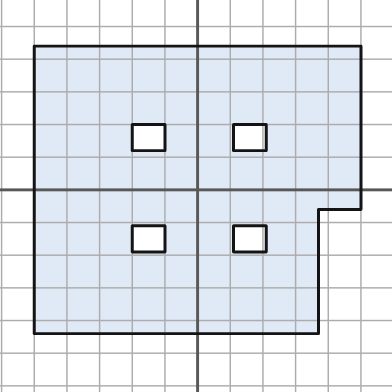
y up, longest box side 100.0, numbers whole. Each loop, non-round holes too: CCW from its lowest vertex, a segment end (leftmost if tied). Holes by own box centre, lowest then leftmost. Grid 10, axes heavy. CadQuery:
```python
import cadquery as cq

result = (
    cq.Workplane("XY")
    .moveTo(-50.0, -44.0)
    .lineTo(37.0, -44.0)
    .lineTo(37.0, -6.0)
    .lineTo(50.0, -6.0)
    .lineTo(50.0, 44.0)
    .lineTo(-50.0, 44.0)
    .close()
    .moveTo(-20.0, -19.0)
    .lineTo(-10.0, -19.0)
    .lineTo(-10.0, -11.0)
    .lineTo(-20.0, -11.0)
    .close()
    .moveTo(11.0, -19.0)
    .lineTo(21.0, -19.0)
    .lineTo(21.0, -11.0)
    .lineTo(11.0, -11.0)
    .close()
    .moveTo(-20.0, 12.0)
    .lineTo(-10.0, 12.0)
    .lineTo(-10.0, 20.0)
    .lineTo(-20.0, 20.0)
    .close()
    .moveTo(11.0, 12.0)
    .lineTo(21.0, 12.0)
    .lineTo(21.0, 20.0)
    .lineTo(11.0, 20.0)
    .close()
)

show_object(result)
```